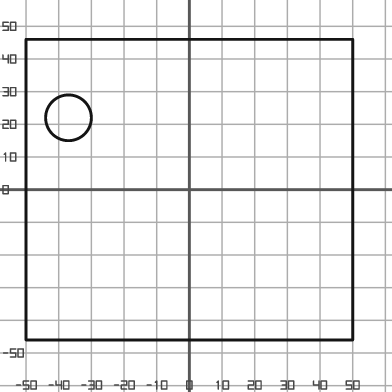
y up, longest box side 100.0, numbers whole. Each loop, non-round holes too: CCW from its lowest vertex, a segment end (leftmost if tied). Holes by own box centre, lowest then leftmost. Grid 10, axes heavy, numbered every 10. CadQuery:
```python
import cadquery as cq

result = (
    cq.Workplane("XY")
    .moveTo(-50.0, -46.0)
    .lineTo(50.0, -46.0)
    .lineTo(50.0, 46.0)
    .lineTo(-50.0, 46.0)
    .close()
    .moveTo(-37.0, 22.0)
    .circle(7.0)
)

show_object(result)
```